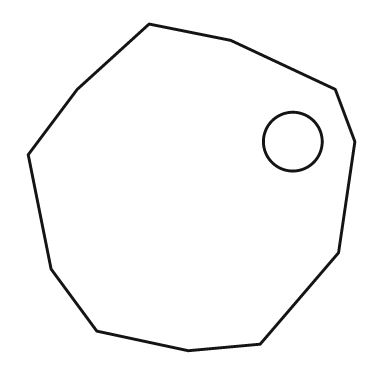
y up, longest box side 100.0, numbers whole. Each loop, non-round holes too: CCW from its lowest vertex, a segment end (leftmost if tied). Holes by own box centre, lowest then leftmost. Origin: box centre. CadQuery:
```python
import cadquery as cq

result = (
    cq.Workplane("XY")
    .moveTo(-1.0, -50.0)
    .lineTo(21.0, -48.0)
    .lineTo(45.0, -20.0)
    .lineTo(50.0, 14.0)
    .lineTo(44.0, 30.0)
    .lineTo(12.0, 45.0)
    .lineTo(-13.0, 50.0)
    .lineTo(-35.0, 30.0)
    .lineTo(-50.0, 10.0)
    .lineTo(-43.0, -25.0)
    .lineTo(-29.0, -44.0)
    .close()
    .moveTo(31.0, 14.0)
    .circle(9.0)
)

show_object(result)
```